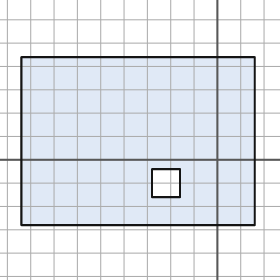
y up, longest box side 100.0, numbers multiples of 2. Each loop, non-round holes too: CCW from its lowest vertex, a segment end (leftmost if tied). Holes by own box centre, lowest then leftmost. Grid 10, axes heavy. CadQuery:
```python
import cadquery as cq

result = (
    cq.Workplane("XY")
    .moveTo(-84.0, -28.0)
    .lineTo(16.0, -28.0)
    .lineTo(16.0, 44.0)
    .lineTo(-84.0, 44.0)
    .close()
    .moveTo(-28.0, -16.0)
    .lineTo(-16.0, -16.0)
    .lineTo(-16.0, -4.0)
    .lineTo(-28.0, -4.0)
    .close()
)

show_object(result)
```